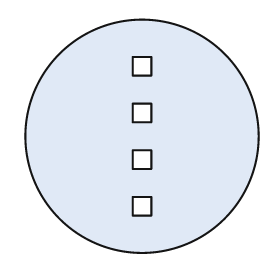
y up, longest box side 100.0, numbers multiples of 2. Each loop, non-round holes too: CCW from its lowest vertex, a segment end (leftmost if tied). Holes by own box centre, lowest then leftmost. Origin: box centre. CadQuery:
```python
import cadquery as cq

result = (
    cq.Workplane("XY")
    .moveTo(0.0, 0.0)
    .circle(50.0)
    .moveTo(-4.0, -34.0)
    .lineTo(4.0, -34.0)
    .lineTo(4.0, -26.0)
    .lineTo(-4.0, -26.0)
    .close()
    .moveTo(-4.0, -14.0)
    .lineTo(4.0, -14.0)
    .lineTo(4.0, -6.0)
    .lineTo(-4.0, -6.0)
    .close()
    .moveTo(-4.0, 6.0)
    .lineTo(4.0, 6.0)
    .lineTo(4.0, 14.0)
    .lineTo(-4.0, 14.0)
    .close()
    .moveTo(-4.0, 26.0)
    .lineTo(4.0, 26.0)
    .lineTo(4.0, 34.0)
    .lineTo(-4.0, 34.0)
    .close()
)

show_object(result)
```